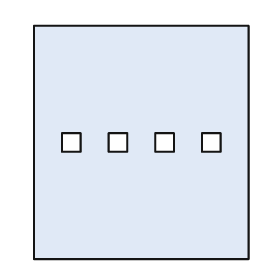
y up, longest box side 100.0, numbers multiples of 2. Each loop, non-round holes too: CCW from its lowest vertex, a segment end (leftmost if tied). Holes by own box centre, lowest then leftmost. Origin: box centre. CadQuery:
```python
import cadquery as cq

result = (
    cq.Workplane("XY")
    .moveTo(-46.0, -50.0)
    .lineTo(46.0, -50.0)
    .lineTo(46.0, 50.0)
    .lineTo(-46.0, 50.0)
    .close()
    .moveTo(-34.0, -4.0)
    .lineTo(-26.0, -4.0)
    .lineTo(-26.0, 4.0)
    .lineTo(-34.0, 4.0)
    .close()
    .moveTo(-14.0, -4.0)
    .lineTo(-6.0, -4.0)
    .lineTo(-6.0, 4.0)
    .lineTo(-14.0, 4.0)
    .close()
    .moveTo(6.0, -4.0)
    .lineTo(14.0, -4.0)
    .lineTo(14.0, 4.0)
    .lineTo(6.0, 4.0)
    .close()
    .moveTo(26.0, -4.0)
    .lineTo(34.0, -4.0)
    .lineTo(34.0, 4.0)
    .lineTo(26.0, 4.0)
    .close()
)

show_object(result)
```